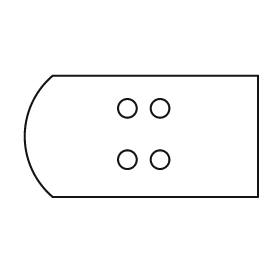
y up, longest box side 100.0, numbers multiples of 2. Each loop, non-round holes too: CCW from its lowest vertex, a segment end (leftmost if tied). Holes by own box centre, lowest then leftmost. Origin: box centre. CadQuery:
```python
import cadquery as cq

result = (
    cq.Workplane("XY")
    .moveTo(-38.0, -26.0)
    .lineTo(50.0, -26.0)
    .lineTo(50.0, 26.0)
    .lineTo(-38.0, 26.0)
    .threePointArc((-50.0, 0.0), (-38.0, -26.0))
    .close()
    .moveTo(-6.0, -10.0)
    .circle(4.0)
    .moveTo(8.0, -10.0)
    .circle(4.0)
    .moveTo(-6.0, 12.0)
    .circle(4.0)
    .moveTo(8.0, 12.0)
    .circle(4.0)
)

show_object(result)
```